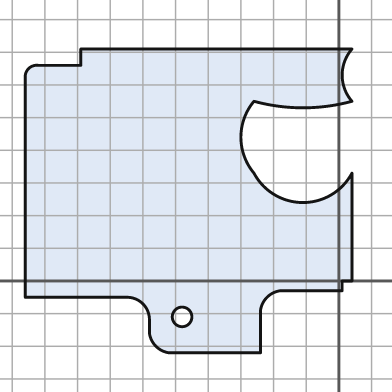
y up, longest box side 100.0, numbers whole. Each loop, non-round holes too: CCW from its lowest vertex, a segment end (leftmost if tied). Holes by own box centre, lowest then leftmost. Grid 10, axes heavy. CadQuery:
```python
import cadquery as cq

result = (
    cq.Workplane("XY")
    .moveTo(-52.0, -22.0)
    .lineTo(-24.0, -22.0)
    .lineTo(-24.0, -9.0)
    .threePointArc((-22.0, -5.0), (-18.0, -3.0))
    .lineTo(1.0, -3.0)
    .lineTo(1.0, 0.0)
    .lineTo(4.0, 0.0)
    .lineTo(4.0, 33.0)
    .threePointArc((-11.0, 24.0), (-26.0, 33.0))
    .threePointArc((-30.0, 44.0), (-26.0, 55.0))
    .threePointArc((-11.0, 53.0), (4.0, 55.0))
    .threePointArc((1.0, 63.0), (4.0, 71.0))
    .lineTo(-79.0, 71.0)
    .lineTo(-79.0, 66.0)
    .lineTo(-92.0, 66.0)
    .threePointArc((-95.0, 65.0), (-96.0, 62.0))
    .lineTo(-96.0, -5.0)
    .lineTo(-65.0, -5.0)
    .threePointArc((-60.0, -7.0), (-58.0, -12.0))
    .lineTo(-58.0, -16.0)
    .threePointArc((-56.0, -20.0), (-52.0, -22.0))
    .close()
    .moveTo(-48.0, -11.0)
    .circle(3.0)
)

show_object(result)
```